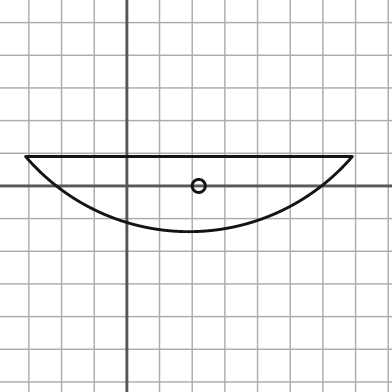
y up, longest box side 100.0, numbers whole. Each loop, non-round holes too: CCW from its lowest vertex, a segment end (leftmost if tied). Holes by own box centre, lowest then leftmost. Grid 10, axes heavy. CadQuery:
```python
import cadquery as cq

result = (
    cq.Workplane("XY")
    .moveTo(-31.0, 9.0)
    .threePointArc((19.0, -14.0), (69.0, 9.0))
    .close()
    .moveTo(22.0, 0.0)
    .circle(2.0)
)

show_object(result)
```